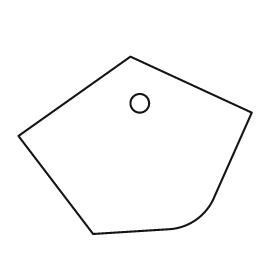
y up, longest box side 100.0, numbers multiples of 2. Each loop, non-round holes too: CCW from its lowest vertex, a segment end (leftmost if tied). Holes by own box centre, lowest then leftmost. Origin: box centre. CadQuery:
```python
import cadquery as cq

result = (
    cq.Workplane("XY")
    .moveTo(-18.0, -38.0)
    .lineTo(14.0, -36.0)
    .threePointArc((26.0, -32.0), (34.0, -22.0))
    .lineTo(50.0, 14.0)
    .lineTo(-2.0, 38.0)
    .lineTo(-50.0, 4.0)
    .close()
    .moveTo(2.0, 18.0)
    .circle(4.0)
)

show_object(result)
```